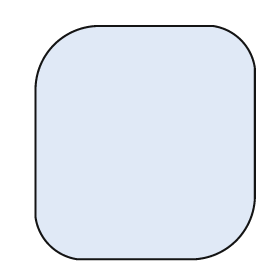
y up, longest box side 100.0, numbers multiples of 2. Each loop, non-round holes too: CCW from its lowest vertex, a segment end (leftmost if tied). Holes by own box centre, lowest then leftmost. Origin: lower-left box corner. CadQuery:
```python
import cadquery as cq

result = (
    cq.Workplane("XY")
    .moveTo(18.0, 0.0)
    .lineTo(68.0, 0.0)
    .threePointArc((86.0, 8.0), (94.0, 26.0))
    .lineTo(94.0, 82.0)
    .threePointArc((88.0, 94.0), (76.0, 100.0))
    .lineTo(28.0, 100.0)
    .threePointArc((8.0, 92.0), (0.0, 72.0))
    .lineTo(0.0, 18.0)
    .threePointArc((6.0, 6.0), (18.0, 0.0))
    .close()
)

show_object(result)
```